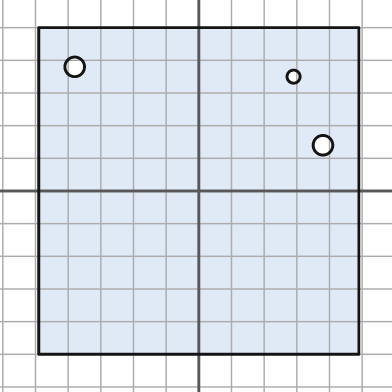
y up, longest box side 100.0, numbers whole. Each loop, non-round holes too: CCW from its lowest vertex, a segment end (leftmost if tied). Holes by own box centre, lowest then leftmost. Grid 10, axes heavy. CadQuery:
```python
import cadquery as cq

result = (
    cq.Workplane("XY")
    .moveTo(-49.0, -50.0)
    .lineTo(49.0, -50.0)
    .lineTo(49.0, 50.0)
    .lineTo(-49.0, 50.0)
    .close()
    .moveTo(38.0, 14.0)
    .circle(3.0)
    .moveTo(29.0, 35.0)
    .circle(2.0)
    .moveTo(-38.0, 38.0)
    .circle(3.0)
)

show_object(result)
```